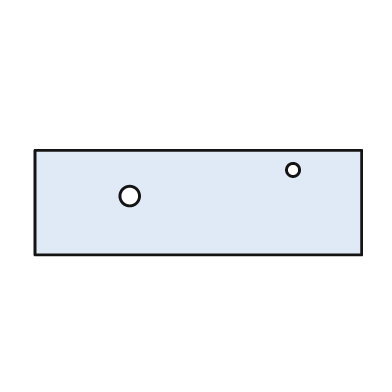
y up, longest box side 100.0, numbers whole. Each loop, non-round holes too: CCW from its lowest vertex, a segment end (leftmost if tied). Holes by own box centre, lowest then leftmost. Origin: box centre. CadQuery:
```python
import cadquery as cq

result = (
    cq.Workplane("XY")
    .moveTo(-50.0, -16.0)
    .lineTo(50.0, -16.0)
    .lineTo(50.0, 16.0)
    .lineTo(-50.0, 16.0)
    .close()
    .moveTo(-21.0, 2.0)
    .circle(3.0)
    .moveTo(29.0, 10.0)
    .circle(2.0)
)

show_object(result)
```